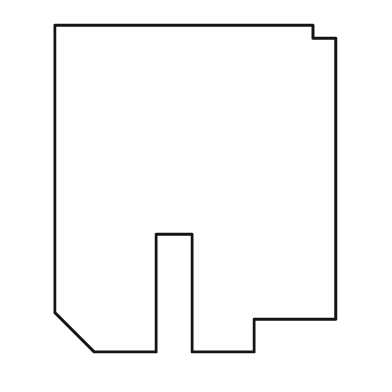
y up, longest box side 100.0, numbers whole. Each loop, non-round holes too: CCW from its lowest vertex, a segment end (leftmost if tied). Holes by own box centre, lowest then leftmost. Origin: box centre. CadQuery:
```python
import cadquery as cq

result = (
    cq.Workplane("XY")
    .moveTo(-31.0, -50.0)
    .lineTo(-12.0, -50.0)
    .lineTo(-12.0, -14.0)
    .lineTo(-1.0, -14.0)
    .lineTo(-1.0, -50.0)
    .lineTo(18.0, -50.0)
    .lineTo(18.0, -40.0)
    .lineTo(43.0, -40.0)
    .lineTo(43.0, 46.0)
    .lineTo(36.0, 46.0)
    .lineTo(36.0, 50.0)
    .lineTo(-43.0, 50.0)
    .lineTo(-43.0, -38.0)
    .close()
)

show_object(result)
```